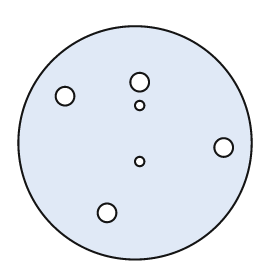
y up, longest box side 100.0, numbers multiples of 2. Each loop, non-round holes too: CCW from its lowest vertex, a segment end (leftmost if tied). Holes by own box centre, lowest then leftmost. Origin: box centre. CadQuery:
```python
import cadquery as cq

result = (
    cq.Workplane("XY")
    .moveTo(0.0, 0.0)
    .circle(50.0)
    .moveTo(-12.0, -30.0)
    .circle(4.0)
    .moveTo(2.0, -8.0)
    .circle(2.0)
    .moveTo(38.0, -2.0)
    .circle(4.0)
    .moveTo(2.0, 16.0)
    .circle(2.0)
    .moveTo(-30.0, 20.0)
    .circle(4.0)
    .moveTo(2.0, 26.0)
    .circle(4.0)
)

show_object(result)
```